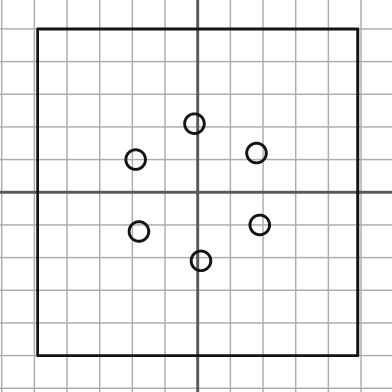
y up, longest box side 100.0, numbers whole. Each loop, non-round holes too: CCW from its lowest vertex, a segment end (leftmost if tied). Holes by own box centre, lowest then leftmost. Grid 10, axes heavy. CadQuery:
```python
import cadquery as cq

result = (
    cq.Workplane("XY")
    .moveTo(-49.0, -50.0)
    .lineTo(49.0, -50.0)
    .lineTo(49.0, 50.0)
    .lineTo(-49.0, 50.0)
    .close()
    .moveTo(1.0, -21.0)
    .circle(3.0)
    .moveTo(-18.0, -12.0)
    .circle(3.0)
    .moveTo(19.0, -10.0)
    .circle(3.0)
    .moveTo(-19.0, 10.0)
    .circle(3.0)
    .moveTo(18.0, 12.0)
    .circle(3.0)
    .moveTo(-1.0, 21.0)
    .circle(3.0)
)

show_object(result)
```